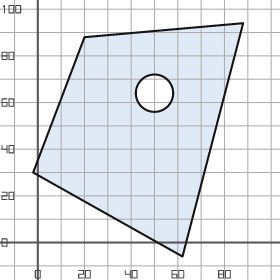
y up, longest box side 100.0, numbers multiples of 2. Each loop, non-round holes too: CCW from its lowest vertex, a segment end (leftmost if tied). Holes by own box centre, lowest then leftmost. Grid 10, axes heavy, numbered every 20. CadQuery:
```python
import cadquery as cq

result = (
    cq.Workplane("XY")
    .moveTo(62.0, -6.0)
    .lineTo(88.0, 94.0)
    .lineTo(20.0, 88.0)
    .lineTo(-2.0, 30.0)
    .close()
    .moveTo(50.0, 64.0)
    .circle(8.0)
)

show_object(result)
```